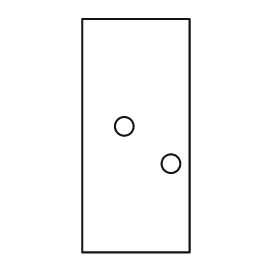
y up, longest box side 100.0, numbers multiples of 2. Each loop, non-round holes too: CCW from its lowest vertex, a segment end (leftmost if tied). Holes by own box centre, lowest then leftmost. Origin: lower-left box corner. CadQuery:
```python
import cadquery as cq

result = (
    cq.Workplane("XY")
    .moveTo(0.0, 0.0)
    .lineTo(46.0, 0.0)
    .lineTo(46.0, 100.0)
    .lineTo(0.0, 100.0)
    .close()
    .moveTo(38.0, 38.0)
    .circle(4.0)
    .moveTo(18.0, 54.0)
    .circle(4.0)
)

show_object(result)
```